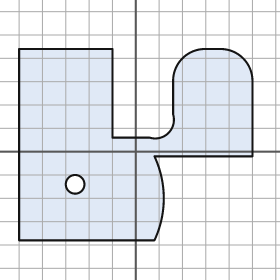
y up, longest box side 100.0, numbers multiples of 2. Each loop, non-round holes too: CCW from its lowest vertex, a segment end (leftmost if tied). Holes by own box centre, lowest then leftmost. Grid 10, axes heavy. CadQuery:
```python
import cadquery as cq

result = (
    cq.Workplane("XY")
    .moveTo(-50.0, -38.0)
    .lineTo(8.0, -38.0)
    .threePointArc((12.0, -20.0), (8.0, -2.0))
    .lineTo(50.0, -2.0)
    .lineTo(50.0, 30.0)
    .threePointArc((46.0, 40.0), (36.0, 44.0))
    .lineTo(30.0, 44.0)
    .threePointArc((20.0, 40.0), (16.0, 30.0))
    .lineTo(16.0, 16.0)
    .threePointArc((14.0, 8.0), (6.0, 6.0))
    .lineTo(-10.0, 6.0)
    .lineTo(-10.0, 44.0)
    .lineTo(-50.0, 44.0)
    .close()
    .moveTo(-26.0, -14.0)
    .circle(4.0)
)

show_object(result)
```